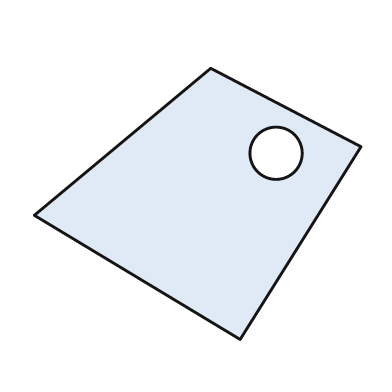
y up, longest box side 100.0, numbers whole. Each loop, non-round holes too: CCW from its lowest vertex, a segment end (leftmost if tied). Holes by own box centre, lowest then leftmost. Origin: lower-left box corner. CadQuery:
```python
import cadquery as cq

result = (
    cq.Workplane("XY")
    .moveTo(63.0, 0.0)
    .lineTo(100.0, 59.0)
    .lineTo(54.0, 83.0)
    .lineTo(0.0, 38.0)
    .close()
    .moveTo(74.0, 57.0)
    .circle(8.0)
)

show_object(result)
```